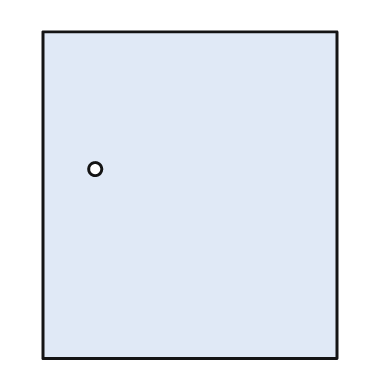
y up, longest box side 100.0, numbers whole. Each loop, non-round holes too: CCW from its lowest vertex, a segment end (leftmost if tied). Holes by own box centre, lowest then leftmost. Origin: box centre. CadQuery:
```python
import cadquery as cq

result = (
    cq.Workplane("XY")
    .moveTo(-45.0, -50.0)
    .lineTo(45.0, -50.0)
    .lineTo(45.0, 50.0)
    .lineTo(-45.0, 50.0)
    .close()
    .moveTo(-29.0, 8.0)
    .circle(2.0)
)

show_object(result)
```